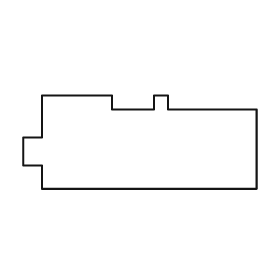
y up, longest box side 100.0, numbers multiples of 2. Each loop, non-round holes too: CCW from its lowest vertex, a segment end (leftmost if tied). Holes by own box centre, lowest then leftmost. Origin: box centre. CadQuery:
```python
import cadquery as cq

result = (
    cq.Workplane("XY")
    .moveTo(-42.0, -20.0)
    .lineTo(50.0, -20.0)
    .lineTo(50.0, 14.0)
    .lineTo(12.0, 14.0)
    .lineTo(12.0, 20.0)
    .lineTo(6.0, 20.0)
    .lineTo(6.0, 14.0)
    .lineTo(-12.0, 14.0)
    .lineTo(-12.0, 20.0)
    .lineTo(-42.0, 20.0)
    .lineTo(-42.0, 2.0)
    .lineTo(-50.0, 2.0)
    .lineTo(-50.0, -10.0)
    .lineTo(-42.0, -10.0)
    .close()
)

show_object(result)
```